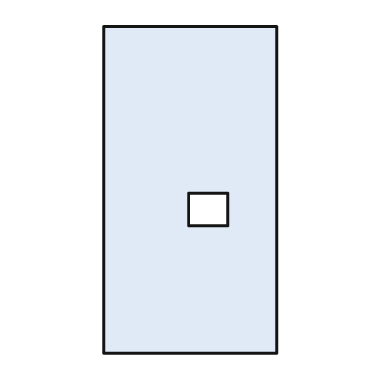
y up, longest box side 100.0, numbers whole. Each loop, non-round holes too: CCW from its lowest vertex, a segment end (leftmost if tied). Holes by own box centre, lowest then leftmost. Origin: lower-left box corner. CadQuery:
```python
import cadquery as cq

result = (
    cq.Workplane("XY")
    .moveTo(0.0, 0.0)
    .lineTo(53.0, 0.0)
    .lineTo(53.0, 100.0)
    .lineTo(0.0, 100.0)
    .close()
    .moveTo(26.0, 39.0)
    .lineTo(38.0, 39.0)
    .lineTo(38.0, 49.0)
    .lineTo(26.0, 49.0)
    .close()
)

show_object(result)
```